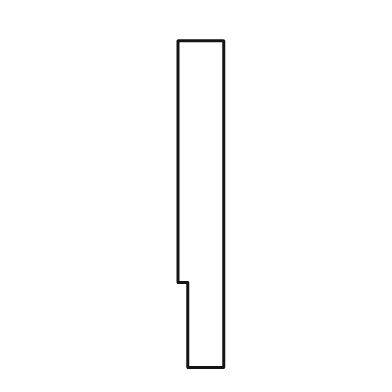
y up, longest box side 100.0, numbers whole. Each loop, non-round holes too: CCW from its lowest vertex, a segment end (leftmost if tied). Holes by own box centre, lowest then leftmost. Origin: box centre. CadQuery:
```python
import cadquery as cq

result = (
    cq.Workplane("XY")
    .moveTo(-4.0, -50.0)
    .lineTo(7.0, -50.0)
    .lineTo(7.0, 50.0)
    .lineTo(-7.0, 50.0)
    .lineTo(-7.0, -24.0)
    .lineTo(-4.0, -24.0)
    .close()
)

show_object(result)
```